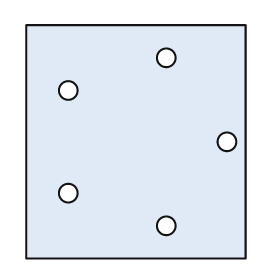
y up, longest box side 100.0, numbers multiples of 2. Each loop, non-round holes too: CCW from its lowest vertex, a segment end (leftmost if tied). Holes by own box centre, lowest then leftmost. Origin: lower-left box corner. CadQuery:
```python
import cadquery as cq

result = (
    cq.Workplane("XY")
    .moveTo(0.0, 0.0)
    .lineTo(94.0, 0.0)
    .lineTo(94.0, 100.0)
    .lineTo(0.0, 100.0)
    .close()
    .moveTo(60.0, 14.0)
    .circle(4.0)
    .moveTo(18.0, 28.0)
    .circle(4.0)
    .moveTo(86.0, 50.0)
    .circle(4.0)
    .moveTo(18.0, 72.0)
    .circle(4.0)
    .moveTo(60.0, 86.0)
    .circle(4.0)
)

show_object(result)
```